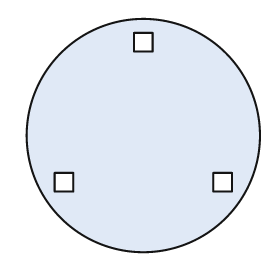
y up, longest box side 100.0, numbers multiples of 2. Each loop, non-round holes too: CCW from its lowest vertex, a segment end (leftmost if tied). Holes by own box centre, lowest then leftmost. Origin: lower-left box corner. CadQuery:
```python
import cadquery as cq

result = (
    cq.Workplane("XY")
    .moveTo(50.0, 50.0)
    .circle(50.0)
    .moveTo(12.0, 26.0)
    .lineTo(20.0, 26.0)
    .lineTo(20.0, 34.0)
    .lineTo(12.0, 34.0)
    .close()
    .moveTo(80.0, 26.0)
    .lineTo(88.0, 26.0)
    .lineTo(88.0, 34.0)
    .lineTo(80.0, 34.0)
    .close()
    .moveTo(46.0, 86.0)
    .lineTo(54.0, 86.0)
    .lineTo(54.0, 94.0)
    .lineTo(46.0, 94.0)
    .close()
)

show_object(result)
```